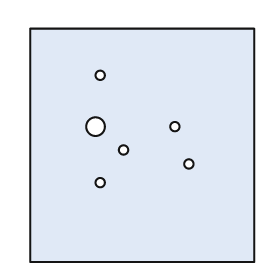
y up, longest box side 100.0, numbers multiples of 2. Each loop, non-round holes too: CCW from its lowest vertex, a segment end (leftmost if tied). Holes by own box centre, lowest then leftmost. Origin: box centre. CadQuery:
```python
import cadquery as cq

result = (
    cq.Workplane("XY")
    .moveTo(-48.0, -50.0)
    .lineTo(48.0, -50.0)
    .lineTo(48.0, 50.0)
    .lineTo(-48.0, 50.0)
    .close()
    .moveTo(-18.0, -16.0)
    .circle(2.0)
    .moveTo(20.0, -8.0)
    .circle(2.0)
    .moveTo(-8.0, -2.0)
    .circle(2.0)
    .moveTo(-20.0, 8.0)
    .circle(4.0)
    .moveTo(14.0, 8.0)
    .circle(2.0)
    .moveTo(-18.0, 30.0)
    .circle(2.0)
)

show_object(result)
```